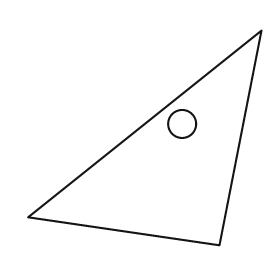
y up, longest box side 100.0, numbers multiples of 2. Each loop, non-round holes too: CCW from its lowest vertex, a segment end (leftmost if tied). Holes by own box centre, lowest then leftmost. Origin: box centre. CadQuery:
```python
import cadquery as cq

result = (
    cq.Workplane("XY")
    .moveTo(32.0, -46.0)
    .lineTo(50.0, 46.0)
    .lineTo(-50.0, -34.0)
    .close()
    .moveTo(16.0, 6.0)
    .circle(6.0)
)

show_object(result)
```